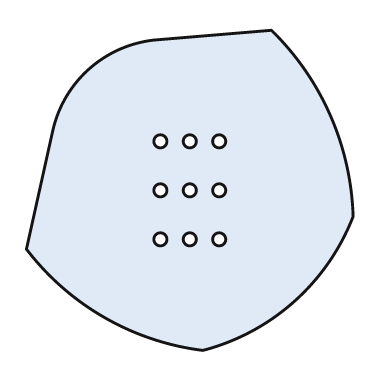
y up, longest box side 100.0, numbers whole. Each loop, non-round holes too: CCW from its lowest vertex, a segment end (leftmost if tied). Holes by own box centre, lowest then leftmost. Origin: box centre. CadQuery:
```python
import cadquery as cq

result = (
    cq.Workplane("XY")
    .moveTo(4.0, -49.0)
    .threePointArc((32.0, -34.0), (50.0, -8.0))
    .threePointArc((43.0, 23.0), (25.0, 49.0))
    .lineTo(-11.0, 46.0)
    .threePointArc((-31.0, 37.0), (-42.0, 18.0))
    .lineTo(-50.0, -18.0)
    .threePointArc((-26.0, -39.0), (4.0, -49.0))
    .close()
    .moveTo(-9.0, -15.0)
    .circle(2.0)
    .moveTo(0.0, -15.0)
    .circle(2.0)
    .moveTo(9.0, -15.0)
    .circle(2.0)
    .moveTo(-9.0, 0.0)
    .circle(2.0)
    .moveTo(0.0, 0.0)
    .circle(2.0)
    .moveTo(9.0, 0.0)
    .circle(2.0)
    .moveTo(-9.0, 15.0)
    .circle(2.0)
    .moveTo(0.0, 15.0)
    .circle(2.0)
    .moveTo(9.0, 15.0)
    .circle(2.0)
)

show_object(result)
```